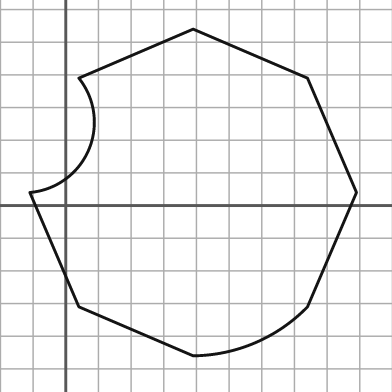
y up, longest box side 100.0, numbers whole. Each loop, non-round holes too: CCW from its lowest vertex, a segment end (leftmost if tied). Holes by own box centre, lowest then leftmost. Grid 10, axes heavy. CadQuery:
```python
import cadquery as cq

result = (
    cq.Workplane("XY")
    .moveTo(39.0, -46.0)
    .threePointArc((58.0, -42.0), (74.0, -31.0))
    .lineTo(89.0, 4.0)
    .lineTo(74.0, 39.0)
    .lineTo(39.0, 54.0)
    .lineTo(4.0, 39.0)
    .threePointArc((7.0, 17.0), (-11.0, 4.0))
    .lineTo(4.0, -31.0)
    .close()
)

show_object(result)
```